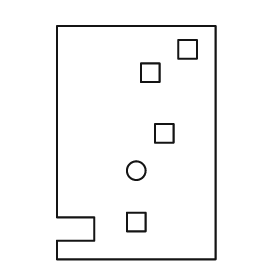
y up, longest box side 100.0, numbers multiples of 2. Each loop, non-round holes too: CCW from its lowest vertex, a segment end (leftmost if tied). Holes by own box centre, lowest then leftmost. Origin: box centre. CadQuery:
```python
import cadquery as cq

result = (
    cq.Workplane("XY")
    .moveTo(-34.0, -50.0)
    .lineTo(34.0, -50.0)
    .lineTo(34.0, 50.0)
    .lineTo(-34.0, 50.0)
    .lineTo(-34.0, -32.0)
    .lineTo(-18.0, -32.0)
    .lineTo(-18.0, -42.0)
    .lineTo(-34.0, -42.0)
    .close()
    .moveTo(-4.0, -38.0)
    .lineTo(4.0, -38.0)
    .lineTo(4.0, -30.0)
    .lineTo(-4.0, -30.0)
    .close()
    .moveTo(0.0, -12.0)
    .circle(4.0)
    .moveTo(8.0, 0.0)
    .lineTo(16.0, 0.0)
    .lineTo(16.0, 8.0)
    .lineTo(8.0, 8.0)
    .close()
    .moveTo(2.0, 26.0)
    .lineTo(10.0, 26.0)
    .lineTo(10.0, 34.0)
    .lineTo(2.0, 34.0)
    .close()
    .moveTo(18.0, 36.0)
    .lineTo(26.0, 36.0)
    .lineTo(26.0, 44.0)
    .lineTo(18.0, 44.0)
    .close()
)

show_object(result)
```